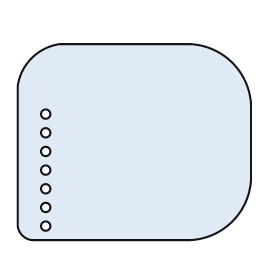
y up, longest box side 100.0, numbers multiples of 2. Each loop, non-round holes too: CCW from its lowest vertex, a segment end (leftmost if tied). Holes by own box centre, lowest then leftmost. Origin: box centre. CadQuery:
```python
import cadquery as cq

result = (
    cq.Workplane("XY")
    .moveTo(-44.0, -42.0)
    .lineTo(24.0, -42.0)
    .threePointArc((42.0, -34.0), (50.0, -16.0))
    .lineTo(50.0, 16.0)
    .threePointArc((42.0, 34.0), (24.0, 42.0))
    .lineTo(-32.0, 42.0)
    .threePointArc((-44.0, 36.0), (-50.0, 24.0))
    .lineTo(-50.0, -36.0)
    .threePointArc((-48.0, -40.0), (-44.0, -42.0))
    .close()
    .moveTo(-38.0, -36.0)
    .circle(2.0)
    .moveTo(-38.0, -28.0)
    .circle(2.0)
    .moveTo(-38.0, -20.0)
    .circle(2.0)
    .moveTo(-38.0, -12.0)
    .circle(2.0)
    .moveTo(-38.0, -4.0)
    .circle(2.0)
    .moveTo(-38.0, 4.0)
    .circle(2.0)
    .moveTo(-38.0, 12.0)
    .circle(2.0)
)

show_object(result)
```